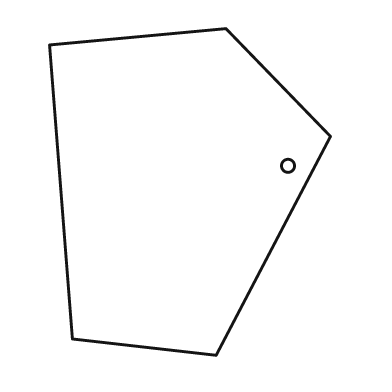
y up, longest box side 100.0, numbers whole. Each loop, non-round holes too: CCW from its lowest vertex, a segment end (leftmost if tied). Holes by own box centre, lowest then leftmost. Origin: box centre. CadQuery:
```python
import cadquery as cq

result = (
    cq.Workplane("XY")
    .moveTo(8.0, -50.0)
    .lineTo(43.0, 17.0)
    .lineTo(11.0, 50.0)
    .lineTo(-43.0, 45.0)
    .lineTo(-36.0, -45.0)
    .close()
    .moveTo(30.0, 8.0)
    .circle(2.0)
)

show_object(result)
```